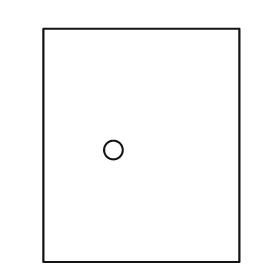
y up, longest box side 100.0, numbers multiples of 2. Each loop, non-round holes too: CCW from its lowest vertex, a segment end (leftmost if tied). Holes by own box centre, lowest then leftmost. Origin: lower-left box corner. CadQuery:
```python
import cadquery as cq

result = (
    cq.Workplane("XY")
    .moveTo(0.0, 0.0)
    .lineTo(84.0, 0.0)
    .lineTo(84.0, 100.0)
    .lineTo(0.0, 100.0)
    .close()
    .moveTo(30.0, 48.0)
    .circle(4.0)
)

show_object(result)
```